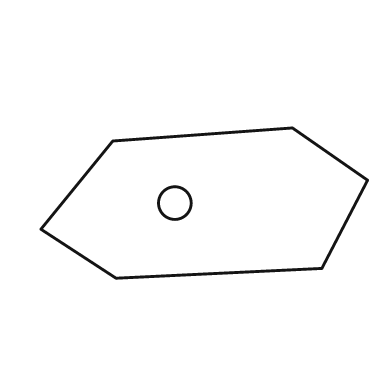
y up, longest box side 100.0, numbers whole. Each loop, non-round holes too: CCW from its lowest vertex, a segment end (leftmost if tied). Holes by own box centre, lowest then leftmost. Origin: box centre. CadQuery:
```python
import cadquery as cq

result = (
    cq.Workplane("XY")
    .moveTo(-27.0, -23.0)
    .lineTo(36.0, -20.0)
    .lineTo(50.0, 7.0)
    .lineTo(27.0, 23.0)
    .lineTo(-28.0, 19.0)
    .lineTo(-50.0, -8.0)
    .close()
    .moveTo(-9.0, 0.0)
    .circle(5.0)
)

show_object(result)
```